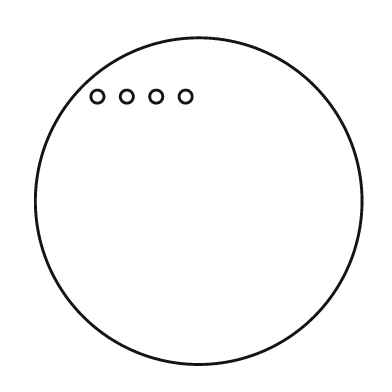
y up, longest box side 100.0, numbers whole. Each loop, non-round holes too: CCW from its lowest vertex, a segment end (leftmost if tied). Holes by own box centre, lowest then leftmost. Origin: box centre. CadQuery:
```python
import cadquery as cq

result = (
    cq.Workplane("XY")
    .moveTo(0.0, 0.0)
    .circle(50.0)
    .moveTo(-31.0, 32.0)
    .circle(2.0)
    .moveTo(-22.0, 32.0)
    .circle(2.0)
    .moveTo(-13.0, 32.0)
    .circle(2.0)
    .moveTo(-4.0, 32.0)
    .circle(2.0)
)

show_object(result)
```